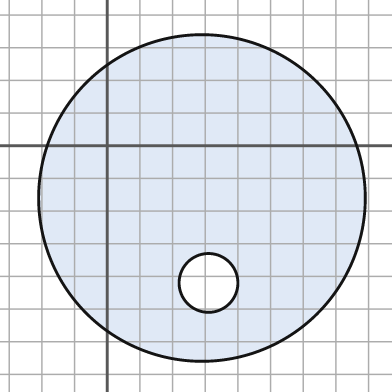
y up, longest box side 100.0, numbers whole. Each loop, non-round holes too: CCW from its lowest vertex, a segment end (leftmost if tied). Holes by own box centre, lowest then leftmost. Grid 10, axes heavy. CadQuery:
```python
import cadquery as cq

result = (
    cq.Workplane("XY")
    .moveTo(29.0, -16.0)
    .circle(50.0)
    .moveTo(31.0, -42.0)
    .circle(9.0)
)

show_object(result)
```